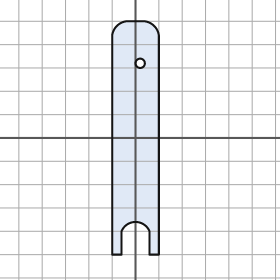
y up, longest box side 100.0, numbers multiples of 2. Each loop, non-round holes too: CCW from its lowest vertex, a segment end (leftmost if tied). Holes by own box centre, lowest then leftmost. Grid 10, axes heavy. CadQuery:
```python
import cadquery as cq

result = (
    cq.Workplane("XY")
    .moveTo(-10.0, -50.0)
    .lineTo(-6.0, -50.0)
    .lineTo(-6.0, -40.0)
    .threePointArc((0.0, -36.0), (6.0, -40.0))
    .lineTo(6.0, -50.0)
    .lineTo(10.0, -50.0)
    .lineTo(10.0, 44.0)
    .threePointArc((8.0, 48.0), (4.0, 50.0))
    .lineTo(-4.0, 50.0)
    .threePointArc((-8.0, 48.0), (-10.0, 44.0))
    .close()
    .moveTo(2.0, 32.0)
    .circle(2.0)
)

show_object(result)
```